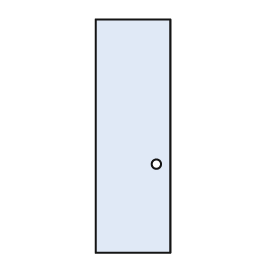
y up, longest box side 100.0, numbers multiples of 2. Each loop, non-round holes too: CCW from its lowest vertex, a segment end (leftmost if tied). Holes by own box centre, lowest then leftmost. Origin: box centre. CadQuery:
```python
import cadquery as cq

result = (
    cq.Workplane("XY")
    .moveTo(-16.0, -50.0)
    .lineTo(16.0, -50.0)
    .lineTo(16.0, 50.0)
    .lineTo(-16.0, 50.0)
    .close()
    .moveTo(10.0, -12.0)
    .circle(2.0)
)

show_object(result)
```